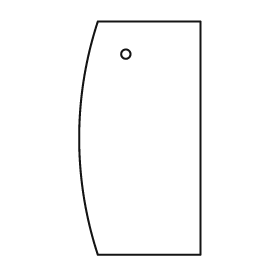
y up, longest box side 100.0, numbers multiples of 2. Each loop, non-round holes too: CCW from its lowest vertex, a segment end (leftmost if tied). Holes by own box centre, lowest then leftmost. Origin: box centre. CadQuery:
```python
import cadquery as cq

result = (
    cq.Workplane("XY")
    .moveTo(-18.0, -50.0)
    .lineTo(26.0, -50.0)
    .lineTo(26.0, 50.0)
    .lineTo(-18.0, 50.0)
    .threePointArc((-26.0, 0.0), (-18.0, -50.0))
    .close()
    .moveTo(-6.0, 36.0)
    .circle(2.0)
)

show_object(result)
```